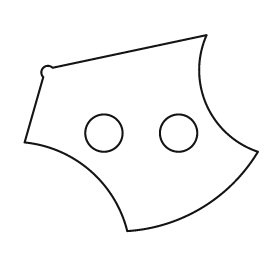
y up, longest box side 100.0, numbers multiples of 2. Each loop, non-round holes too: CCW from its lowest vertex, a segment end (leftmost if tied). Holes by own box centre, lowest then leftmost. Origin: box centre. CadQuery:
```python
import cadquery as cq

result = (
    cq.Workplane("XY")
    .moveTo(-6.0, -42.0)
    .threePointArc((26.0, -32.0), (50.0, -8.0))
    .threePointArc((28.0, 12.0), (28.0, 42.0))
    .lineTo(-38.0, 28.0)
    .threePointArc((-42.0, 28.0), (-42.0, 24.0))
    .lineTo(-50.0, -4.0)
    .threePointArc((-22.0, -16.0), (-6.0, -42.0))
    .close()
    .moveTo(-16.0, 0.0)
    .circle(8.0)
    .moveTo(16.0, 0.0)
    .circle(8.0)
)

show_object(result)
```